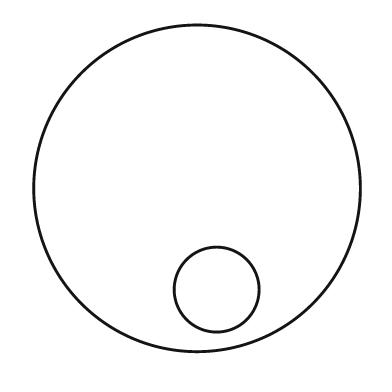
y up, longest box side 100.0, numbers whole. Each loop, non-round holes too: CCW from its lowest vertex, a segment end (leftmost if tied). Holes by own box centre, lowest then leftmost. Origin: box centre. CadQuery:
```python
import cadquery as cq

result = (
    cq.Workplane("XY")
    .moveTo(0.0, 0.0)
    .circle(50.0)
    .moveTo(6.0, -31.0)
    .circle(13.0)
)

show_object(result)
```